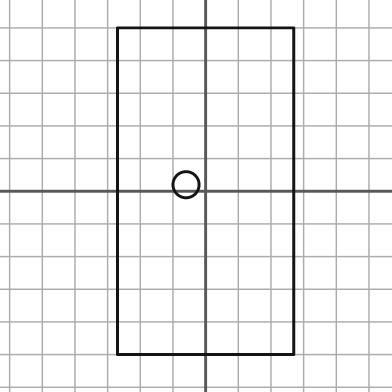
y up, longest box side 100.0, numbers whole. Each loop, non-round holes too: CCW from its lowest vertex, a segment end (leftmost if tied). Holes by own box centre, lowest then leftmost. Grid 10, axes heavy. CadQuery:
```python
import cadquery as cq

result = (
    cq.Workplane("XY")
    .moveTo(-27.0, -50.0)
    .lineTo(27.0, -50.0)
    .lineTo(27.0, 50.0)
    .lineTo(-27.0, 50.0)
    .close()
    .moveTo(-6.0, 2.0)
    .circle(4.0)
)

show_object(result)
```